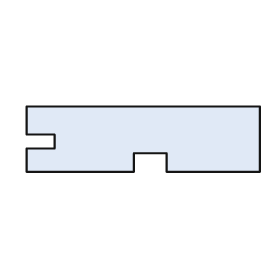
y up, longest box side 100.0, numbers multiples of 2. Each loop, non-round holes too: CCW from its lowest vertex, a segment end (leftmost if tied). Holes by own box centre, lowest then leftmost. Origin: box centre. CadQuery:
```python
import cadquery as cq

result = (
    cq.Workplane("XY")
    .moveTo(-50.0, -14.0)
    .lineTo(-4.0, -14.0)
    .lineTo(-4.0, -6.0)
    .lineTo(10.0, -6.0)
    .lineTo(10.0, -14.0)
    .lineTo(50.0, -14.0)
    .lineTo(50.0, 14.0)
    .lineTo(-50.0, 14.0)
    .lineTo(-50.0, 2.0)
    .lineTo(-38.0, 2.0)
    .lineTo(-38.0, -4.0)
    .lineTo(-50.0, -4.0)
    .close()
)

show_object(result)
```